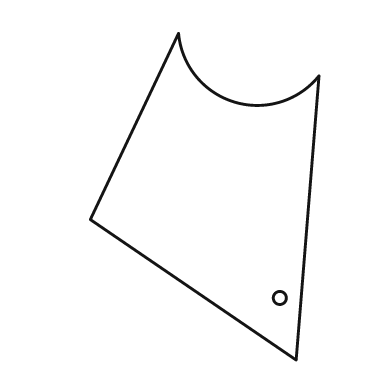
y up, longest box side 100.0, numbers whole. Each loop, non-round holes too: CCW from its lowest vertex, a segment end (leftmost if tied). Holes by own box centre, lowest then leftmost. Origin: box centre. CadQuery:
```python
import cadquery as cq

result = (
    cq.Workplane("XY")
    .moveTo(28.0, -50.0)
    .lineTo(35.0, 37.0)
    .threePointArc((9.0, 29.0), (-8.0, 50.0))
    .lineTo(-35.0, -7.0)
    .close()
    .moveTo(23.0, -31.0)
    .circle(2.0)
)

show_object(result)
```